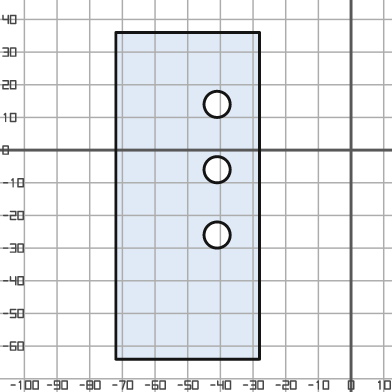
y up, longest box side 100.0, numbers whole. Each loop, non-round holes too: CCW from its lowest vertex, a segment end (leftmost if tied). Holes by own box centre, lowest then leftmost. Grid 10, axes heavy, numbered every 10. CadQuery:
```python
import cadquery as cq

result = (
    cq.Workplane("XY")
    .moveTo(-72.0, -64.0)
    .lineTo(-28.0, -64.0)
    .lineTo(-28.0, 36.0)
    .lineTo(-72.0, 36.0)
    .close()
    .moveTo(-41.0, -26.0)
    .circle(4.0)
    .moveTo(-41.0, -6.0)
    .circle(4.0)
    .moveTo(-41.0, 14.0)
    .circle(4.0)
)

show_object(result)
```